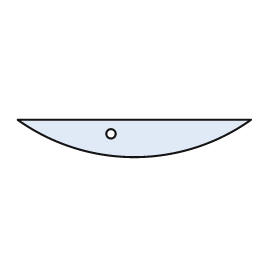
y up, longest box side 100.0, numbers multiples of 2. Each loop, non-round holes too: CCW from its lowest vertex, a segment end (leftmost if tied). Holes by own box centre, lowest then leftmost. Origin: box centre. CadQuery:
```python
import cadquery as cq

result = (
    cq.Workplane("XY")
    .moveTo(-50.0, 8.0)
    .threePointArc((0.0, -8.0), (50.0, 8.0))
    .close()
    .moveTo(-10.0, 2.0)
    .circle(2.0)
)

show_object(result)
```